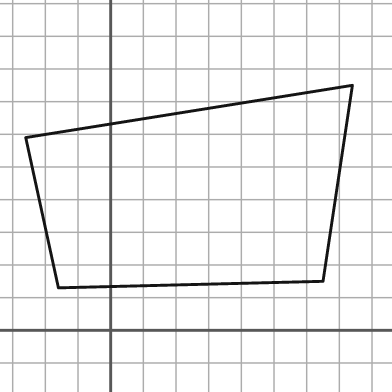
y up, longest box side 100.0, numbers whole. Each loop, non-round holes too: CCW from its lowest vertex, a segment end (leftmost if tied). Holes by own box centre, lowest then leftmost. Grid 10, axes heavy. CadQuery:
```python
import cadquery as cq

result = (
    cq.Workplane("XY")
    .moveTo(-16.0, 13.0)
    .lineTo(65.0, 15.0)
    .lineTo(74.0, 75.0)
    .lineTo(-26.0, 59.0)
    .close()
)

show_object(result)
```